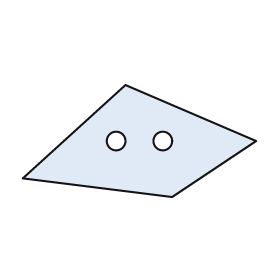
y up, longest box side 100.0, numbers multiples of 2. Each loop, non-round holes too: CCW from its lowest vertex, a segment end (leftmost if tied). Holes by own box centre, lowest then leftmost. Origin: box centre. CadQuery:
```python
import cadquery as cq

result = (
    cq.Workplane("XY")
    .moveTo(14.0, -24.0)
    .lineTo(50.0, 0.0)
    .lineTo(-6.0, 24.0)
    .lineTo(-50.0, -16.0)
    .close()
    .moveTo(-10.0, 0.0)
    .circle(4.0)
    .moveTo(10.0, 0.0)
    .circle(4.0)
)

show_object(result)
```